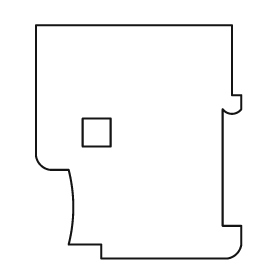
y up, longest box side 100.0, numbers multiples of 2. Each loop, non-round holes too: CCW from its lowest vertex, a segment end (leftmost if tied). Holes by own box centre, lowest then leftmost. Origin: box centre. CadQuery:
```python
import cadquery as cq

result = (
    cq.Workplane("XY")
    .moveTo(-16.0, -50.0)
    .lineTo(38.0, -50.0)
    .threePointArc((42.0, -48.0), (44.0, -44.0))
    .lineTo(44.0, -36.0)
    .lineTo(36.0, -36.0)
    .lineTo(36.0, 14.0)
    .threePointArc((40.0, 12.0), (44.0, 14.0))
    .lineTo(44.0, 20.0)
    .lineTo(40.0, 20.0)
    .lineTo(40.0, 50.0)
    .lineTo(-44.0, 50.0)
    .lineTo(-44.0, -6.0)
    .threePointArc((-42.0, -10.0), (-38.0, -12.0))
    .lineTo(-30.0, -12.0)
    .threePointArc((-28.0, -28.0), (-30.0, -44.0))
    .lineTo(-16.0, -44.0)
    .close()
    .moveTo(-24.0, -2.0)
    .lineTo(-12.0, -2.0)
    .lineTo(-12.0, 10.0)
    .lineTo(-24.0, 10.0)
    .close()
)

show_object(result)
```